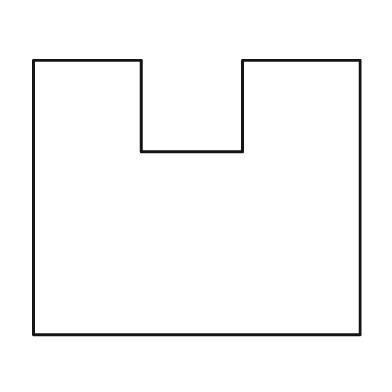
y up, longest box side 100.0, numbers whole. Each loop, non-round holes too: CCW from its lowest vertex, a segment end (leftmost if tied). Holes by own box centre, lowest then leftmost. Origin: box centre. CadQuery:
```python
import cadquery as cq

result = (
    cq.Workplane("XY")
    .moveTo(-50.0, -42.0)
    .lineTo(50.0, -42.0)
    .lineTo(50.0, 42.0)
    .lineTo(14.0, 42.0)
    .lineTo(14.0, 14.0)
    .lineTo(-17.0, 14.0)
    .lineTo(-17.0, 42.0)
    .lineTo(-50.0, 42.0)
    .close()
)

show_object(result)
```